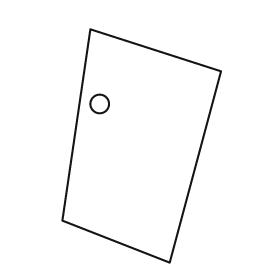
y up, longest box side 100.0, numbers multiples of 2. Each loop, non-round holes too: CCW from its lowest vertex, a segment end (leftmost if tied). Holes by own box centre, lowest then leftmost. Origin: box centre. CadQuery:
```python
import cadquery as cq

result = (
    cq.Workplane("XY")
    .moveTo(12.0, -50.0)
    .lineTo(34.0, 32.0)
    .lineTo(-22.0, 50.0)
    .lineTo(-34.0, -32.0)
    .close()
    .moveTo(-18.0, 18.0)
    .circle(4.0)
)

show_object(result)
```